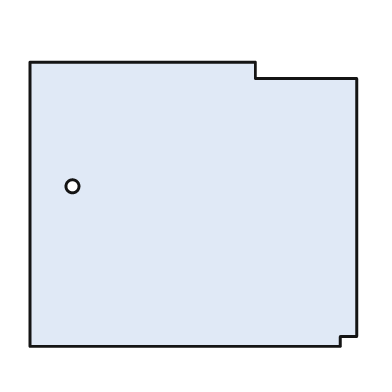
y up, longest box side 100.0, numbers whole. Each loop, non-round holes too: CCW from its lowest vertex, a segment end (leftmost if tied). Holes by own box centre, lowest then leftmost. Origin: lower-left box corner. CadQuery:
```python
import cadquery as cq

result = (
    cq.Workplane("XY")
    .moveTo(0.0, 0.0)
    .lineTo(95.0, 0.0)
    .lineTo(95.0, 3.0)
    .lineTo(100.0, 3.0)
    .lineTo(100.0, 82.0)
    .lineTo(69.0, 82.0)
    .lineTo(69.0, 87.0)
    .lineTo(0.0, 87.0)
    .close()
    .moveTo(13.0, 49.0)
    .circle(2.0)
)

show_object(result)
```